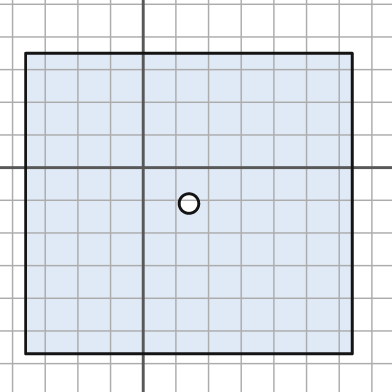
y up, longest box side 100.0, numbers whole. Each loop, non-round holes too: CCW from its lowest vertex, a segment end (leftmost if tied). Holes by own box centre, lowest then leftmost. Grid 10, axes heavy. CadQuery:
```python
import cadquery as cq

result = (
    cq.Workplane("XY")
    .moveTo(-36.0, -57.0)
    .lineTo(64.0, -57.0)
    .lineTo(64.0, 35.0)
    .lineTo(-36.0, 35.0)
    .close()
    .moveTo(14.0, -11.0)
    .circle(3.0)
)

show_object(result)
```